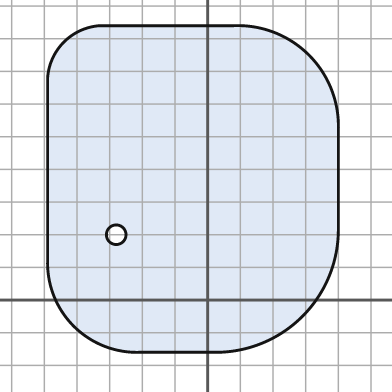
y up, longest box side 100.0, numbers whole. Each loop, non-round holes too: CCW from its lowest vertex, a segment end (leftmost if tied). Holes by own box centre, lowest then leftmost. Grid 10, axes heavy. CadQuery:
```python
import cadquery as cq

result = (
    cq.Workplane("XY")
    .moveTo(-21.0, -16.0)
    .lineTo(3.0, -16.0)
    .threePointArc((29.0, -5.0), (40.0, 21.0))
    .lineTo(40.0, 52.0)
    .threePointArc((31.0, 75.0), (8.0, 84.0))
    .lineTo(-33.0, 84.0)
    .threePointArc((-44.0, 79.0), (-49.0, 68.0))
    .lineTo(-49.0, 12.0)
    .threePointArc((-41.0, -8.0), (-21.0, -16.0))
    .close()
    .moveTo(-28.0, 20.0)
    .circle(3.0)
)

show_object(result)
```